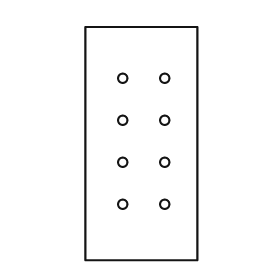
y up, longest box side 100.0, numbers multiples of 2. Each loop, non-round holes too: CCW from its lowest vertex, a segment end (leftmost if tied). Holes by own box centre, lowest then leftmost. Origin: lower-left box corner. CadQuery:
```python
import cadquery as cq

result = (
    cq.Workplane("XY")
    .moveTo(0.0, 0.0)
    .lineTo(48.0, 0.0)
    .lineTo(48.0, 100.0)
    .lineTo(0.0, 100.0)
    .close()
    .moveTo(16.0, 24.0)
    .circle(2.0)
    .moveTo(34.0, 24.0)
    .circle(2.0)
    .moveTo(16.0, 42.0)
    .circle(2.0)
    .moveTo(34.0, 42.0)
    .circle(2.0)
    .moveTo(16.0, 60.0)
    .circle(2.0)
    .moveTo(34.0, 60.0)
    .circle(2.0)
    .moveTo(16.0, 78.0)
    .circle(2.0)
    .moveTo(34.0, 78.0)
    .circle(2.0)
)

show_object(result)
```